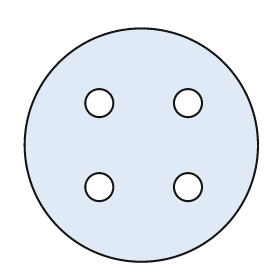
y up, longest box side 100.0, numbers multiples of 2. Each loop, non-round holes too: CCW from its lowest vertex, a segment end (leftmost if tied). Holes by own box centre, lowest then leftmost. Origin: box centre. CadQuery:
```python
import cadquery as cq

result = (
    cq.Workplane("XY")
    .moveTo(0.0, 0.0)
    .circle(50.0)
    .moveTo(-18.0, -18.0)
    .circle(6.0)
    .moveTo(20.0, -18.0)
    .circle(6.0)
    .moveTo(-18.0, 18.0)
    .circle(6.0)
    .moveTo(20.0, 18.0)
    .circle(6.0)
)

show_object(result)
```